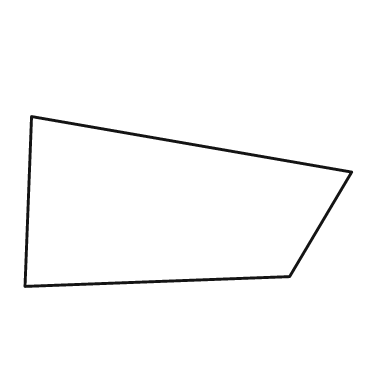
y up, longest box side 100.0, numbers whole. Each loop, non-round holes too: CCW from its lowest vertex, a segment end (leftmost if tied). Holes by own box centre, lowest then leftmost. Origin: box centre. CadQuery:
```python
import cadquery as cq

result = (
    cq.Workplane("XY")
    .moveTo(-50.0, -26.0)
    .lineTo(31.0, -23.0)
    .lineTo(50.0, 9.0)
    .lineTo(-48.0, 26.0)
    .close()
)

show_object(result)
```